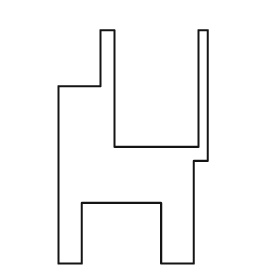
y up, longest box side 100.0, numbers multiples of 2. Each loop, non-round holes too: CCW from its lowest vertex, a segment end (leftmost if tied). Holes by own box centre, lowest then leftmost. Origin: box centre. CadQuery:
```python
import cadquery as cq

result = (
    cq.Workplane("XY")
    .moveTo(-32.0, -50.0)
    .lineTo(-22.0, -50.0)
    .lineTo(-22.0, -24.0)
    .lineTo(12.0, -24.0)
    .lineTo(12.0, -50.0)
    .lineTo(26.0, -50.0)
    .lineTo(26.0, -6.0)
    .lineTo(32.0, -6.0)
    .lineTo(32.0, 50.0)
    .lineTo(28.0, 50.0)
    .lineTo(28.0, 0.0)
    .lineTo(-8.0, 0.0)
    .lineTo(-8.0, 50.0)
    .lineTo(-14.0, 50.0)
    .lineTo(-14.0, 26.0)
    .lineTo(-32.0, 26.0)
    .close()
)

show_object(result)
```